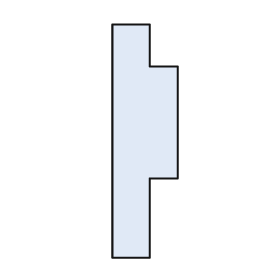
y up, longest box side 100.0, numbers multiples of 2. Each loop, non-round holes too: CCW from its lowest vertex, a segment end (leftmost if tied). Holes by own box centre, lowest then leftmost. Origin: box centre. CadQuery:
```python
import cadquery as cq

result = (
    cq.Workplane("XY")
    .moveTo(-14.0, -50.0)
    .lineTo(2.0, -50.0)
    .lineTo(2.0, -16.0)
    .lineTo(14.0, -16.0)
    .lineTo(14.0, 32.0)
    .lineTo(2.0, 32.0)
    .lineTo(2.0, 50.0)
    .lineTo(-14.0, 50.0)
    .close()
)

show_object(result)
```